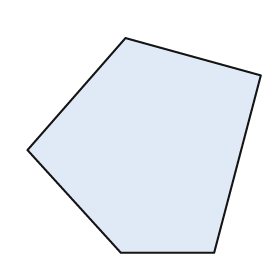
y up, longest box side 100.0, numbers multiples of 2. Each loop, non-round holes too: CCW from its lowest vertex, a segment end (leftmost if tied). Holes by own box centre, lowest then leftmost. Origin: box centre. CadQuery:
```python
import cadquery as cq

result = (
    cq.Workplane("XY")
    .moveTo(-10.0, -46.0)
    .lineTo(30.0, -46.0)
    .lineTo(50.0, 30.0)
    .lineTo(-8.0, 46.0)
    .lineTo(-50.0, -2.0)
    .close()
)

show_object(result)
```